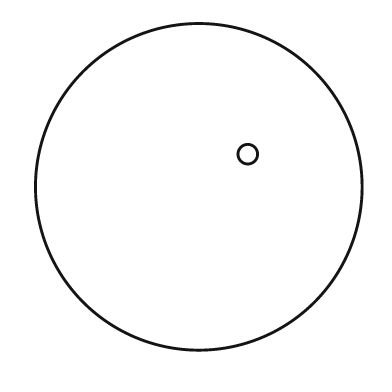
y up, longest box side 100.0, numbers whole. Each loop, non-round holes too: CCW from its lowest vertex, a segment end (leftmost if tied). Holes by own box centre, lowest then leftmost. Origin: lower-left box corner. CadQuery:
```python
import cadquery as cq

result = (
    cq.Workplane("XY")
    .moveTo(50.0, 50.0)
    .circle(50.0)
    .moveTo(65.0, 60.0)
    .circle(3.0)
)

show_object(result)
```